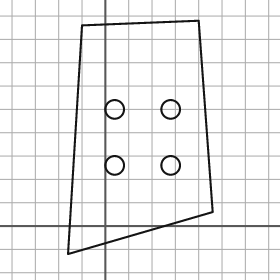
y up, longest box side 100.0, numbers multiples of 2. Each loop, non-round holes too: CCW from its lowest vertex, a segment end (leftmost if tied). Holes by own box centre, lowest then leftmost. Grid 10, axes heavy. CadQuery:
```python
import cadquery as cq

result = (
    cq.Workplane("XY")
    .moveTo(-16.0, -12.0)
    .lineTo(46.0, 6.0)
    .lineTo(40.0, 88.0)
    .lineTo(-10.0, 86.0)
    .close()
    .moveTo(4.0, 26.0)
    .circle(4.0)
    .moveTo(28.0, 26.0)
    .circle(4.0)
    .moveTo(4.0, 50.0)
    .circle(4.0)
    .moveTo(28.0, 50.0)
    .circle(4.0)
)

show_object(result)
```